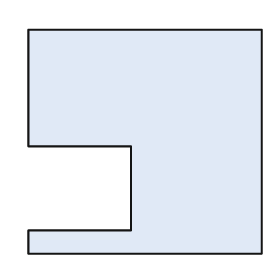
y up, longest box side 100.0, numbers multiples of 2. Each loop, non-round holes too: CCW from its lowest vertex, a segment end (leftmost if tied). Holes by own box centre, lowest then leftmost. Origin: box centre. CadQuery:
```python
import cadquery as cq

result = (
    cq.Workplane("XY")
    .moveTo(-50.0, -48.0)
    .lineTo(50.0, -48.0)
    .lineTo(50.0, 48.0)
    .lineTo(-50.0, 48.0)
    .lineTo(-50.0, -2.0)
    .lineTo(-6.0, -2.0)
    .lineTo(-6.0, -38.0)
    .lineTo(-50.0, -38.0)
    .close()
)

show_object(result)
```